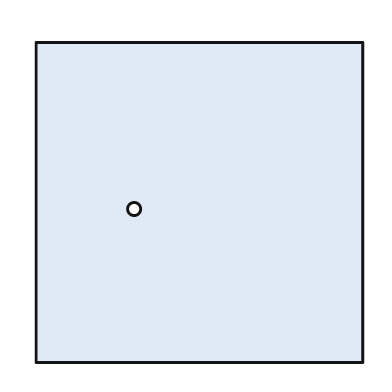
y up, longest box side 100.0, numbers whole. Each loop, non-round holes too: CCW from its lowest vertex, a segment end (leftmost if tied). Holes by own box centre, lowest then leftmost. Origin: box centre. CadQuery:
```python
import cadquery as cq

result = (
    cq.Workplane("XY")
    .moveTo(-50.0, -49.0)
    .lineTo(50.0, -49.0)
    .lineTo(50.0, 49.0)
    .lineTo(-50.0, 49.0)
    .close()
    .moveTo(-20.0, -2.0)
    .circle(2.0)
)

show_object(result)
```